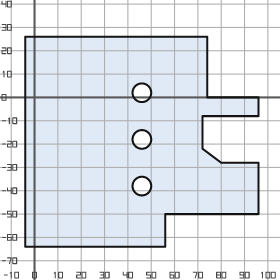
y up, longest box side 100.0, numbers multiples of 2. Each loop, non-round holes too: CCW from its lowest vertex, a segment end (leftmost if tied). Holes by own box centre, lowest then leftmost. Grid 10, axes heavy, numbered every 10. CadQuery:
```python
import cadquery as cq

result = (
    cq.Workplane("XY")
    .moveTo(-4.0, -64.0)
    .lineTo(56.0, -64.0)
    .lineTo(56.0, -50.0)
    .lineTo(96.0, -50.0)
    .lineTo(96.0, -28.0)
    .lineTo(80.0, -28.0)
    .lineTo(72.0, -22.0)
    .lineTo(72.0, -8.0)
    .lineTo(96.0, -8.0)
    .lineTo(96.0, 0.0)
    .lineTo(74.0, 0.0)
    .lineTo(74.0, 26.0)
    .lineTo(-4.0, 26.0)
    .close()
    .moveTo(46.0, -38.0)
    .circle(4.0)
    .moveTo(46.0, -18.0)
    .circle(4.0)
    .moveTo(46.0, 2.0)
    .circle(4.0)
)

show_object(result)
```